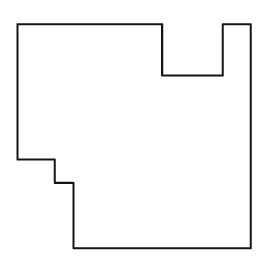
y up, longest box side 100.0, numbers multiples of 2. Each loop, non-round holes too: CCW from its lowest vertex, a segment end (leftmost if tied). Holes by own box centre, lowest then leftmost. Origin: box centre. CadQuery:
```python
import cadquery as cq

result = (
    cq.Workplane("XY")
    .moveTo(-26.0, -48.0)
    .lineTo(50.0, -48.0)
    .lineTo(50.0, 48.0)
    .lineTo(38.0, 48.0)
    .lineTo(38.0, 26.0)
    .lineTo(12.0, 26.0)
    .lineTo(12.0, 48.0)
    .lineTo(-50.0, 48.0)
    .lineTo(-50.0, -10.0)
    .lineTo(-34.0, -10.0)
    .lineTo(-34.0, -20.0)
    .lineTo(-26.0, -20.0)
    .close()
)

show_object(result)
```